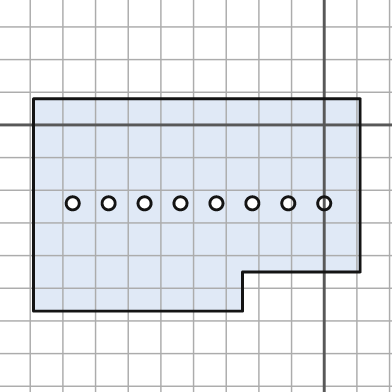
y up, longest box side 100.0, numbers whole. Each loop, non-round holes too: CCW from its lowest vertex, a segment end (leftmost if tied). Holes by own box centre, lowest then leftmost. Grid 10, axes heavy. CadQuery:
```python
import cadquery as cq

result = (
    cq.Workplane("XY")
    .moveTo(-89.0, -57.0)
    .lineTo(-25.0, -57.0)
    .lineTo(-25.0, -45.0)
    .lineTo(11.0, -45.0)
    .lineTo(11.0, 8.0)
    .lineTo(-89.0, 8.0)
    .close()
    .moveTo(-77.0, -24.0)
    .circle(2.0)
    .moveTo(-66.0, -24.0)
    .circle(2.0)
    .moveTo(-55.0, -24.0)
    .circle(2.0)
    .moveTo(-44.0, -24.0)
    .circle(2.0)
    .moveTo(-33.0, -24.0)
    .circle(2.0)
    .moveTo(-22.0, -24.0)
    .circle(2.0)
    .moveTo(-11.0, -24.0)
    .circle(2.0)
    .moveTo(0.0, -24.0)
    .circle(2.0)
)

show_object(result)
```